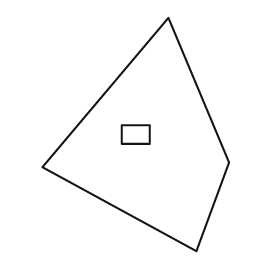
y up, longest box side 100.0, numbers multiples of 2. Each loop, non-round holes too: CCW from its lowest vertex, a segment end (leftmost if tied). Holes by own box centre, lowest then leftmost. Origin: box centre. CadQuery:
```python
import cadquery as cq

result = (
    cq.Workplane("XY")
    .moveTo(26.0, -50.0)
    .lineTo(40.0, -12.0)
    .lineTo(14.0, 50.0)
    .lineTo(-40.0, -14.0)
    .close()
    .moveTo(-6.0, -4.0)
    .lineTo(6.0, -4.0)
    .lineTo(6.0, 4.0)
    .lineTo(-6.0, 4.0)
    .close()
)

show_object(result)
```